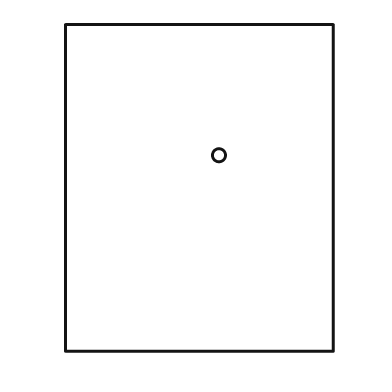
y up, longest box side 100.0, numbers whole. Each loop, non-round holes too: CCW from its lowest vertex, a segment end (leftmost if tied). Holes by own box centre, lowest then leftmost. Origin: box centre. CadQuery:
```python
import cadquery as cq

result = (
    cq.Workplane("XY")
    .moveTo(-41.0, -50.0)
    .lineTo(41.0, -50.0)
    .lineTo(41.0, 50.0)
    .lineTo(-41.0, 50.0)
    .close()
    .moveTo(6.0, 10.0)
    .circle(2.0)
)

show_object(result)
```